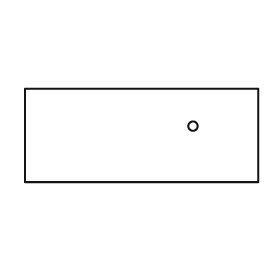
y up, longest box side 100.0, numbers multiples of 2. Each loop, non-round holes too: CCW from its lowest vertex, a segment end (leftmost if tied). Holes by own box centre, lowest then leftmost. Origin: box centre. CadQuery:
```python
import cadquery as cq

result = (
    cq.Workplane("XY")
    .moveTo(-50.0, -20.0)
    .lineTo(50.0, -20.0)
    .lineTo(50.0, 20.0)
    .lineTo(-50.0, 20.0)
    .close()
    .moveTo(22.0, 4.0)
    .circle(2.0)
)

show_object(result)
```